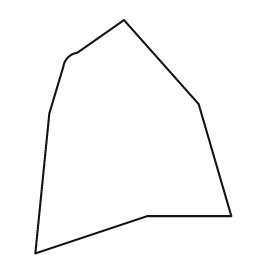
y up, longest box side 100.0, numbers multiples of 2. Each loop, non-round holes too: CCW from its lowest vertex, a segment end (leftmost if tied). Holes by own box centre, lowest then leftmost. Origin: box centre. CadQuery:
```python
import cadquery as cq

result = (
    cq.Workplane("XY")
    .moveTo(-42.0, -50.0)
    .lineTo(6.0, -34.0)
    .lineTo(42.0, -34.0)
    .lineTo(28.0, 14.0)
    .lineTo(-4.0, 50.0)
    .lineTo(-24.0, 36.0)
    .threePointArc((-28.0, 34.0), (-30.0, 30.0))
    .lineTo(-36.0, 10.0)
    .close()
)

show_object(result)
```